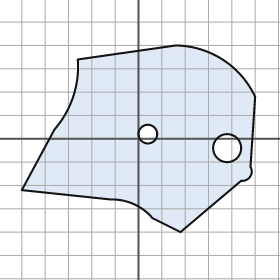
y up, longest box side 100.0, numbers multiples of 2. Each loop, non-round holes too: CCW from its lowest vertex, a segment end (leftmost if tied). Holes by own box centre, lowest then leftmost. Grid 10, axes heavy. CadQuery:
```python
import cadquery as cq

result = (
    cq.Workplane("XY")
    .moveTo(18.0, -40.0)
    .lineTo(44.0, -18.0)
    .threePointArc((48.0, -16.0), (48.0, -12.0))
    .lineTo(50.0, 18.0)
    .threePointArc((36.0, 34.0), (16.0, 40.0))
    .lineTo(-26.0, 34.0)
    .threePointArc((-28.0, 18.0), (-36.0, 4.0))
    .lineTo(-50.0, -22.0)
    .lineTo(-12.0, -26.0)
    .threePointArc((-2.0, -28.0), (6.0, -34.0))
    .close()
    .moveTo(38.0, -4.0)
    .circle(6.0)
    .moveTo(4.0, 2.0)
    .circle(4.0)
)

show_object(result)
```